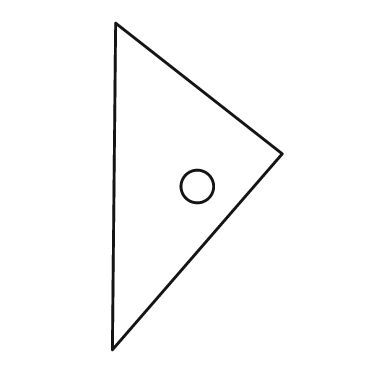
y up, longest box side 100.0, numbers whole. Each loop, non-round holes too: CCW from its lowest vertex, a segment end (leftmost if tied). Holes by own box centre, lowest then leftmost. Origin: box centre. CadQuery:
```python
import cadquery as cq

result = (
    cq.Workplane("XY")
    .moveTo(-26.0, -50.0)
    .lineTo(26.0, 10.0)
    .lineTo(-25.0, 50.0)
    .close()
    .moveTo(0.0, 0.0)
    .circle(5.0)
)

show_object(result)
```